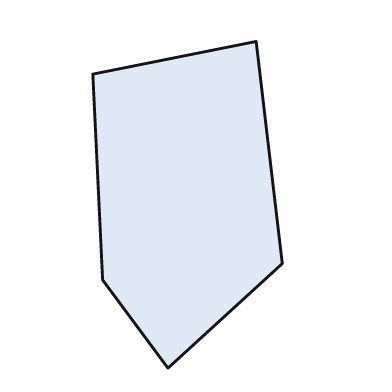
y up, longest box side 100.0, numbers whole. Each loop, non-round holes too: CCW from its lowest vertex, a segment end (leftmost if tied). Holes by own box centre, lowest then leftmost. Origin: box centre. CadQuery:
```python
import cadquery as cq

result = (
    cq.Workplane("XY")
    .moveTo(-6.0, -50.0)
    .lineTo(29.0, -18.0)
    .lineTo(21.0, 50.0)
    .lineTo(-29.0, 40.0)
    .lineTo(-26.0, -23.0)
    .close()
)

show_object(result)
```